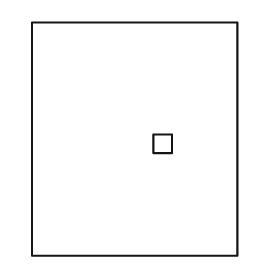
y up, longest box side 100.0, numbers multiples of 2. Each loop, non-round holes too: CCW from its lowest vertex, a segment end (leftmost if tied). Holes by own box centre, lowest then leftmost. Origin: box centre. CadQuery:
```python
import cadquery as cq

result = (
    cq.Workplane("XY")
    .moveTo(-44.0, -50.0)
    .lineTo(44.0, -50.0)
    .lineTo(44.0, 50.0)
    .lineTo(-44.0, 50.0)
    .close()
    .moveTo(8.0, -6.0)
    .lineTo(16.0, -6.0)
    .lineTo(16.0, 2.0)
    .lineTo(8.0, 2.0)
    .close()
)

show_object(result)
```